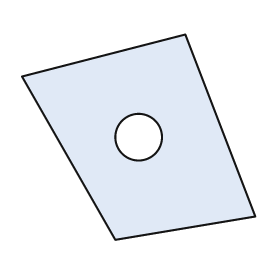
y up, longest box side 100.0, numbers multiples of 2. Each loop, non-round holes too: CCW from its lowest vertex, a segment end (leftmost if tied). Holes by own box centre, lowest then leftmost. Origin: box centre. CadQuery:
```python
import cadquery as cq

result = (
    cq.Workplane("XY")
    .moveTo(-10.0, -44.0)
    .lineTo(50.0, -34.0)
    .lineTo(20.0, 44.0)
    .lineTo(-50.0, 26.0)
    .close()
    .moveTo(0.0, 0.0)
    .circle(10.0)
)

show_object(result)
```